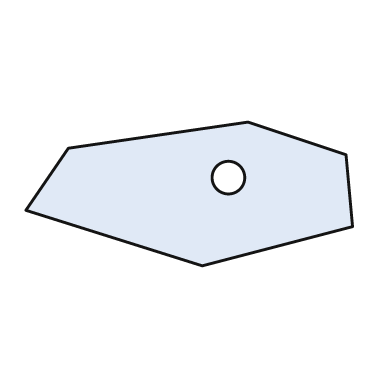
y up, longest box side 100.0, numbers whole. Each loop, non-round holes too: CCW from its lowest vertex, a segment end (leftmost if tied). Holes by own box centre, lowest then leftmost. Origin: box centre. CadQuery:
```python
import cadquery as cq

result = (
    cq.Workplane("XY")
    .moveTo(4.0, -22.0)
    .lineTo(50.0, -10.0)
    .lineTo(48.0, 12.0)
    .lineTo(18.0, 22.0)
    .lineTo(-37.0, 14.0)
    .lineTo(-50.0, -5.0)
    .close()
    .moveTo(12.0, 5.0)
    .circle(5.0)
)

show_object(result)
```